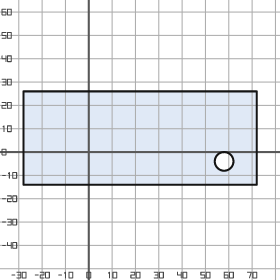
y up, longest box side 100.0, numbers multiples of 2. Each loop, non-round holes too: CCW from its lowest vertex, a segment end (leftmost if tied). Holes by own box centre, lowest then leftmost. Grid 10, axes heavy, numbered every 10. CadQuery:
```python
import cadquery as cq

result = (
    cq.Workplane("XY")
    .moveTo(-28.0, -14.0)
    .lineTo(72.0, -14.0)
    .lineTo(72.0, 26.0)
    .lineTo(-28.0, 26.0)
    .close()
    .moveTo(58.0, -4.0)
    .circle(4.0)
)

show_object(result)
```